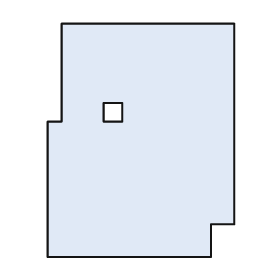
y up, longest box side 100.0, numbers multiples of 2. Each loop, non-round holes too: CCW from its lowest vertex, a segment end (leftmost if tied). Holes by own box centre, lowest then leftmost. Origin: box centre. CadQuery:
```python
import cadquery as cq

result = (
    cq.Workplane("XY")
    .moveTo(-40.0, -50.0)
    .lineTo(30.0, -50.0)
    .lineTo(30.0, -36.0)
    .lineTo(40.0, -36.0)
    .lineTo(40.0, 50.0)
    .lineTo(-34.0, 50.0)
    .lineTo(-34.0, 8.0)
    .lineTo(-40.0, 8.0)
    .close()
    .moveTo(-16.0, 8.0)
    .lineTo(-8.0, 8.0)
    .lineTo(-8.0, 16.0)
    .lineTo(-16.0, 16.0)
    .close()
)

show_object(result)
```